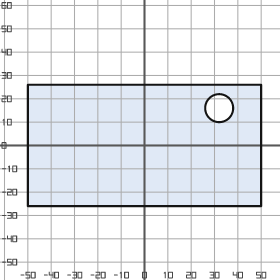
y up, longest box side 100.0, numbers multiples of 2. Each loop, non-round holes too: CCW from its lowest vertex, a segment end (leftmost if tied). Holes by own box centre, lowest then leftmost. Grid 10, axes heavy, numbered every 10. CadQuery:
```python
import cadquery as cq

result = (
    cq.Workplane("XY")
    .moveTo(-50.0, -26.0)
    .lineTo(50.0, -26.0)
    .lineTo(50.0, 26.0)
    .lineTo(-50.0, 26.0)
    .close()
    .moveTo(32.0, 16.0)
    .circle(6.0)
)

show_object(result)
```